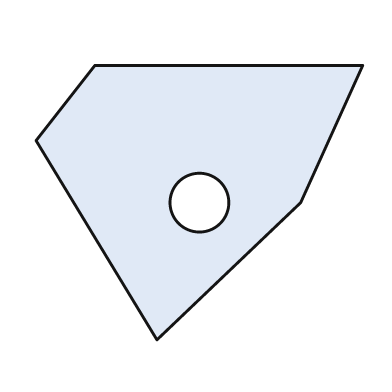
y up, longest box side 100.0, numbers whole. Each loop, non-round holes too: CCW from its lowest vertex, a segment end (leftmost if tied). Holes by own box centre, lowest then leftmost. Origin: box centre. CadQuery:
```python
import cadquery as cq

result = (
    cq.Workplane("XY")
    .moveTo(-13.0, -42.0)
    .lineTo(31.0, 0.0)
    .lineTo(50.0, 42.0)
    .lineTo(-32.0, 42.0)
    .lineTo(-50.0, 19.0)
    .close()
    .moveTo(0.0, 0.0)
    .circle(9.0)
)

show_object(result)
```